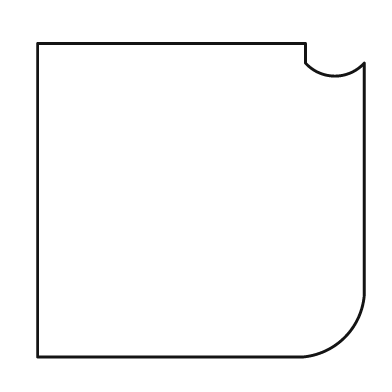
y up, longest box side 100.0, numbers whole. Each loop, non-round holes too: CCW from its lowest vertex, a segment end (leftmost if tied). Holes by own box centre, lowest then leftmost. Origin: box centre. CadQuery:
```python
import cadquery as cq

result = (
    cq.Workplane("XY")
    .moveTo(-50.0, -48.0)
    .lineTo(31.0, -48.0)
    .threePointArc((44.0, -42.0), (50.0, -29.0))
    .lineTo(50.0, 42.0)
    .threePointArc((41.0, 38.0), (32.0, 42.0))
    .lineTo(32.0, 48.0)
    .lineTo(-50.0, 48.0)
    .close()
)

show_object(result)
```